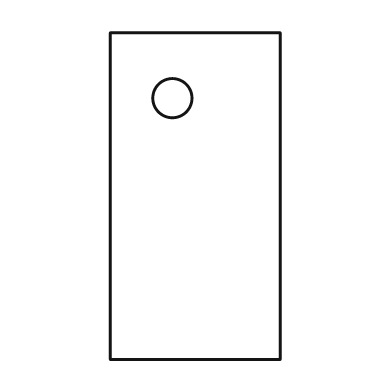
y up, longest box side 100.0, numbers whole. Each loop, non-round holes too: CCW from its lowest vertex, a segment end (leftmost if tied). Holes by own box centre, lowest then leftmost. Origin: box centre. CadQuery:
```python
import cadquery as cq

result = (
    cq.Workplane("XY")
    .moveTo(-26.0, -50.0)
    .lineTo(26.0, -50.0)
    .lineTo(26.0, 50.0)
    .lineTo(-26.0, 50.0)
    .close()
    .moveTo(-7.0, 30.0)
    .circle(6.0)
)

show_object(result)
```